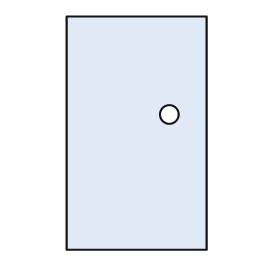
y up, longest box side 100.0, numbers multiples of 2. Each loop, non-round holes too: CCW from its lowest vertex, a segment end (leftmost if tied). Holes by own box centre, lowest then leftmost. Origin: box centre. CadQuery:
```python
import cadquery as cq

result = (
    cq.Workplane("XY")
    .moveTo(-30.0, -50.0)
    .lineTo(30.0, -50.0)
    .lineTo(30.0, 50.0)
    .lineTo(-30.0, 50.0)
    .close()
    .moveTo(14.0, 8.0)
    .circle(4.0)
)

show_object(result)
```